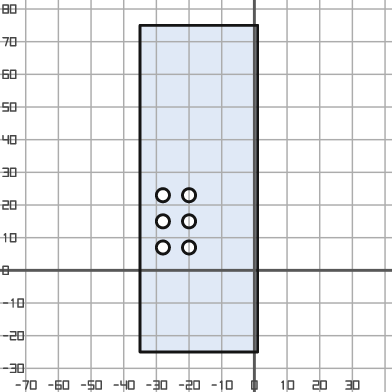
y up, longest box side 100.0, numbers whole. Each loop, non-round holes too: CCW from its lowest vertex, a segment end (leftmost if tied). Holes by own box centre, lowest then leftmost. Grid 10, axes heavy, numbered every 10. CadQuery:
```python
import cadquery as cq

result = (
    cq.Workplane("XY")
    .moveTo(-35.0, -25.0)
    .lineTo(1.0, -25.0)
    .lineTo(1.0, 75.0)
    .lineTo(-35.0, 75.0)
    .close()
    .moveTo(-28.0, 7.0)
    .circle(2.0)
    .moveTo(-20.0, 7.0)
    .circle(2.0)
    .moveTo(-28.0, 15.0)
    .circle(2.0)
    .moveTo(-20.0, 15.0)
    .circle(2.0)
    .moveTo(-28.0, 23.0)
    .circle(2.0)
    .moveTo(-20.0, 23.0)
    .circle(2.0)
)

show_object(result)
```